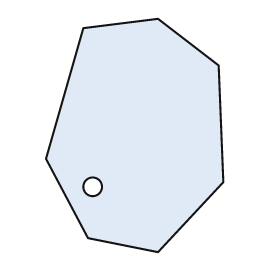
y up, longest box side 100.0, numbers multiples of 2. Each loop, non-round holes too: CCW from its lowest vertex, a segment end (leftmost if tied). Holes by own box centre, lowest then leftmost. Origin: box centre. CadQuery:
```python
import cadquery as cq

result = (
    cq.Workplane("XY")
    .moveTo(10.0, -50.0)
    .lineTo(38.0, -20.0)
    .lineTo(36.0, 30.0)
    .lineTo(10.0, 50.0)
    .lineTo(-22.0, 46.0)
    .lineTo(-38.0, -10.0)
    .lineTo(-20.0, -44.0)
    .close()
    .moveTo(-18.0, -22.0)
    .circle(4.0)
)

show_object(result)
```